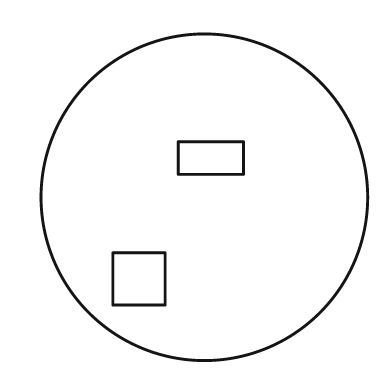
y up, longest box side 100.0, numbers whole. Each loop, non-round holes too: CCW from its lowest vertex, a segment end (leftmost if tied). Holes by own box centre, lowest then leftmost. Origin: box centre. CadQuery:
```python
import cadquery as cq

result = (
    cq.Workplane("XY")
    .moveTo(0.0, 0.0)
    .circle(50.0)
    .moveTo(-28.0, -33.0)
    .lineTo(-12.0, -33.0)
    .lineTo(-12.0, -17.0)
    .lineTo(-28.0, -17.0)
    .close()
    .moveTo(-8.0, 7.0)
    .lineTo(12.0, 7.0)
    .lineTo(12.0, 17.0)
    .lineTo(-8.0, 17.0)
    .close()
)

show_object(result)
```